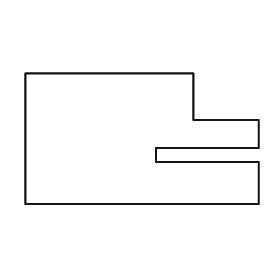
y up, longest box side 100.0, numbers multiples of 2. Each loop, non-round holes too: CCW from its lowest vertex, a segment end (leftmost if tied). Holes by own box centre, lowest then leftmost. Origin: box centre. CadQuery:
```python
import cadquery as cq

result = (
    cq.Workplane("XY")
    .moveTo(-50.0, -28.0)
    .lineTo(50.0, -28.0)
    .lineTo(50.0, -10.0)
    .lineTo(6.0, -10.0)
    .lineTo(6.0, -4.0)
    .lineTo(50.0, -4.0)
    .lineTo(50.0, 8.0)
    .lineTo(22.0, 8.0)
    .lineTo(22.0, 28.0)
    .lineTo(-50.0, 28.0)
    .close()
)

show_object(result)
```